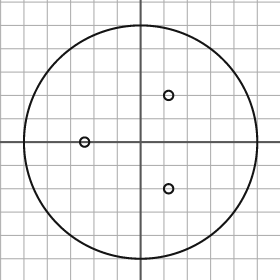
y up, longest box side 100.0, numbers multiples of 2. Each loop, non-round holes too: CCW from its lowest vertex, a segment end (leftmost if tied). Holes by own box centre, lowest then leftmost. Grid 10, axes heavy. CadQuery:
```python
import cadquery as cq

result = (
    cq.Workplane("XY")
    .moveTo(0.0, 0.0)
    .circle(50.0)
    .moveTo(12.0, -20.0)
    .circle(2.0)
    .moveTo(-24.0, 0.0)
    .circle(2.0)
    .moveTo(12.0, 20.0)
    .circle(2.0)
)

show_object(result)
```